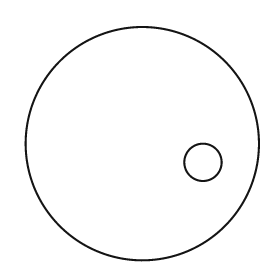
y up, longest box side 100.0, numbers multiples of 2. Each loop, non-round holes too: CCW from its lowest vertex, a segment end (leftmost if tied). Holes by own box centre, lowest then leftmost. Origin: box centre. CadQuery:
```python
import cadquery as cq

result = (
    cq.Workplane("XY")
    .moveTo(0.0, 0.0)
    .circle(50.0)
    .moveTo(26.0, -8.0)
    .circle(8.0)
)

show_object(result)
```